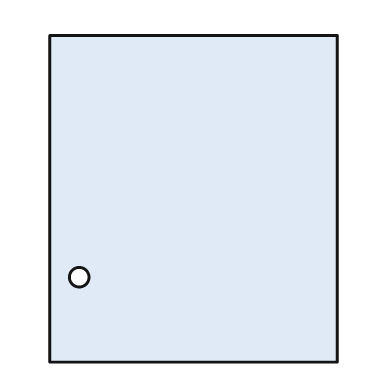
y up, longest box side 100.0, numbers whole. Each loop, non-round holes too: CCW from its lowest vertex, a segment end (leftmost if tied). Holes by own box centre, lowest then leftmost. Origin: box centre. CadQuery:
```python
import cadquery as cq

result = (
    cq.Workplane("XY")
    .moveTo(-44.0, -50.0)
    .lineTo(44.0, -50.0)
    .lineTo(44.0, 50.0)
    .lineTo(-44.0, 50.0)
    .close()
    .moveTo(-35.0, -24.0)
    .circle(3.0)
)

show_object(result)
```